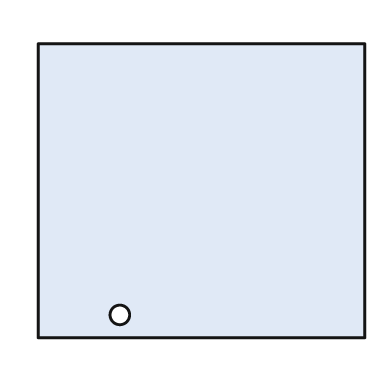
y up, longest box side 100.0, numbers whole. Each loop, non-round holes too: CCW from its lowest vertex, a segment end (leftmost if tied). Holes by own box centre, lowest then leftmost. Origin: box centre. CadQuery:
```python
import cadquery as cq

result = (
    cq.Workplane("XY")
    .moveTo(-50.0, -45.0)
    .lineTo(50.0, -45.0)
    .lineTo(50.0, 45.0)
    .lineTo(-50.0, 45.0)
    .close()
    .moveTo(-25.0, -38.0)
    .circle(3.0)
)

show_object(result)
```